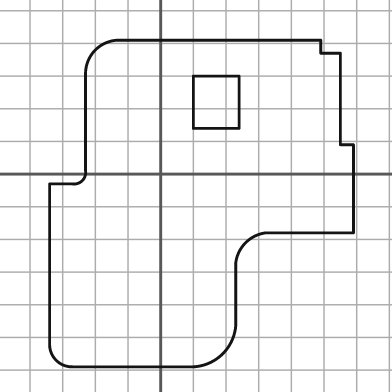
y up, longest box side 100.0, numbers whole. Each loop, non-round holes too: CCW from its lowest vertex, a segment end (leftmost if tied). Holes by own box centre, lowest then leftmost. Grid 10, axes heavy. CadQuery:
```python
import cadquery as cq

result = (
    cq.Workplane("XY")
    .moveTo(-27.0, -59.0)
    .lineTo(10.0, -59.0)
    .threePointArc((19.0, -55.0), (23.0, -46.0))
    .lineTo(23.0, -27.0)
    .threePointArc((26.0, -21.0), (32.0, -18.0))
    .lineTo(59.0, -18.0)
    .lineTo(59.0, 9.0)
    .lineTo(55.0, 9.0)
    .lineTo(55.0, 37.0)
    .lineTo(49.0, 37.0)
    .lineTo(49.0, 41.0)
    .lineTo(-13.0, 41.0)
    .threePointArc((-20.0, 38.0), (-23.0, 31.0))
    .lineTo(-23.0, 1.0)
    .threePointArc((-24.0, -2.0), (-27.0, -3.0))
    .lineTo(-34.0, -3.0)
    .lineTo(-34.0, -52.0)
    .threePointArc((-32.0, -57.0), (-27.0, -59.0))
    .close()
    .moveTo(10.0, 14.0)
    .lineTo(24.0, 14.0)
    .lineTo(24.0, 30.0)
    .lineTo(10.0, 30.0)
    .close()
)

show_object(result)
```